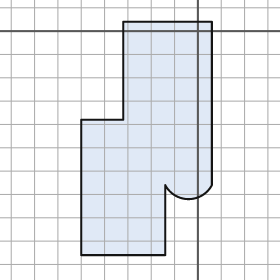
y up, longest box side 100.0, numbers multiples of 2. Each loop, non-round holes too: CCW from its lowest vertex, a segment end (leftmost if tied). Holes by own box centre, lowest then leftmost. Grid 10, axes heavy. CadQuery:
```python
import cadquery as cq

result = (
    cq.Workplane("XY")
    .moveTo(-50.0, -96.0)
    .lineTo(-14.0, -96.0)
    .lineTo(-14.0, -66.0)
    .threePointArc((-4.0, -72.0), (6.0, -66.0))
    .lineTo(6.0, 4.0)
    .lineTo(-32.0, 4.0)
    .lineTo(-32.0, -38.0)
    .lineTo(-50.0, -38.0)
    .close()
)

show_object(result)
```